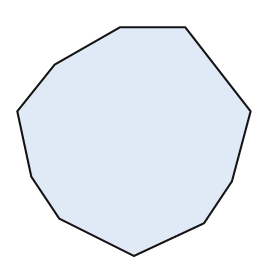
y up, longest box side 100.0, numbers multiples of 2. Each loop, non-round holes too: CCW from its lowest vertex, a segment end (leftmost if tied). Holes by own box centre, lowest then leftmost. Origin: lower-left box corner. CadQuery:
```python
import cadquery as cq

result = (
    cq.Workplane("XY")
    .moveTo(50.0, 0.0)
    .lineTo(80.0, 14.0)
    .lineTo(92.0, 32.0)
    .lineTo(100.0, 62.0)
    .lineTo(72.0, 98.0)
    .lineTo(44.0, 98.0)
    .lineTo(16.0, 82.0)
    .lineTo(0.0, 62.0)
    .lineTo(6.0, 34.0)
    .lineTo(18.0, 16.0)
    .close()
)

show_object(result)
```